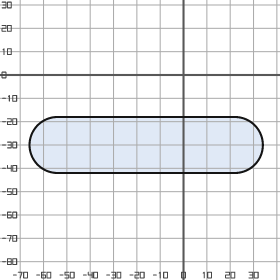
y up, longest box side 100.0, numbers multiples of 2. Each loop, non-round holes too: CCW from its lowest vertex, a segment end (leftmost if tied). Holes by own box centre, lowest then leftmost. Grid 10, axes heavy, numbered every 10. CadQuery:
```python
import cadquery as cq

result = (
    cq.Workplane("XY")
    .moveTo(-54.0, -42.0)
    .lineTo(22.0, -42.0)
    .threePointArc((34.0, -30.0), (22.0, -18.0))
    .lineTo(-54.0, -18.0)
    .threePointArc((-66.0, -30.0), (-54.0, -42.0))
    .close()
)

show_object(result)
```